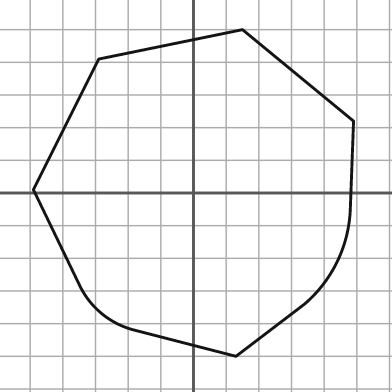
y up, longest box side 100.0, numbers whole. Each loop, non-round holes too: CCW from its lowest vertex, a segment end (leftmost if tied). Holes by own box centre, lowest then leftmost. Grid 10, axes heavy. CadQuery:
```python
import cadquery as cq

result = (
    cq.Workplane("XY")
    .moveTo(13.0, -50.0)
    .lineTo(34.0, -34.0)
    .threePointArc((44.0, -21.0), (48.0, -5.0))
    .lineTo(49.0, 22.0)
    .lineTo(15.0, 50.0)
    .lineTo(-29.0, 41.0)
    .lineTo(-49.0, 1.0)
    .lineTo(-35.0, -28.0)
    .threePointArc((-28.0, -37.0), (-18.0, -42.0))
    .close()
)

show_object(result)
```